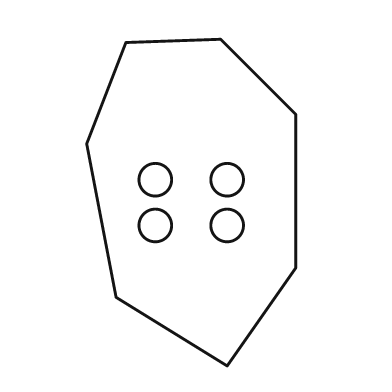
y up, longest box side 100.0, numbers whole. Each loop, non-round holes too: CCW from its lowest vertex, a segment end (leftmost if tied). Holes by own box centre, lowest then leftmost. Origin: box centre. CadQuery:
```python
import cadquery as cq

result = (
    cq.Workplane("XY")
    .moveTo(11.0, -50.0)
    .lineTo(32.0, -20.0)
    .lineTo(32.0, 27.0)
    .lineTo(9.0, 50.0)
    .lineTo(-20.0, 49.0)
    .lineTo(-32.0, 18.0)
    .lineTo(-23.0, -29.0)
    .close()
    .moveTo(-11.0, -7.0)
    .circle(5.0)
    .moveTo(11.0, -7.0)
    .circle(5.0)
    .moveTo(-11.0, 7.0)
    .circle(5.0)
    .moveTo(11.0, 7.0)
    .circle(5.0)
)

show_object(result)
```